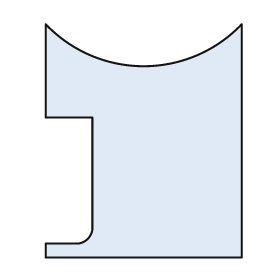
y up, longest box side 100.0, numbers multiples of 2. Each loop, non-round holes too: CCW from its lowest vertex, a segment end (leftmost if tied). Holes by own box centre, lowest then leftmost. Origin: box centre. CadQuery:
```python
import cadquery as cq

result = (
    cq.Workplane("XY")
    .moveTo(-42.0, -50.0)
    .lineTo(42.0, -50.0)
    .lineTo(42.0, 50.0)
    .threePointArc((0.0, 32.0), (-42.0, 50.0))
    .lineTo(-42.0, 10.0)
    .lineTo(-22.0, 10.0)
    .lineTo(-22.0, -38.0)
    .threePointArc((-24.0, -42.0), (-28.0, -44.0))
    .lineTo(-42.0, -44.0)
    .close()
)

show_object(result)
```